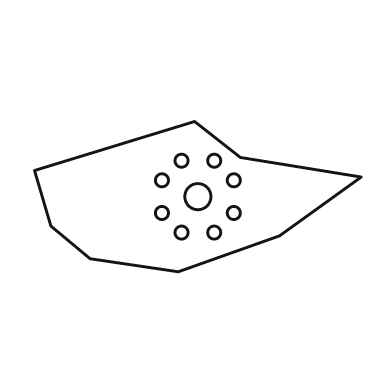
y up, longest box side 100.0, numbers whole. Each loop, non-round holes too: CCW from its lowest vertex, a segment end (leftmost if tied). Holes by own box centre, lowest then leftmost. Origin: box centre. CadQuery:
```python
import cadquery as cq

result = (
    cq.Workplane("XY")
    .moveTo(-6.0, -23.0)
    .lineTo(25.0, -12.0)
    .lineTo(50.0, 6.0)
    .lineTo(13.0, 12.0)
    .lineTo(-1.0, 23.0)
    .lineTo(-50.0, 8.0)
    .lineTo(-45.0, -9.0)
    .lineTo(-33.0, -19.0)
    .close()
    .moveTo(-5.0, -11.0)
    .circle(2.0)
    .moveTo(5.0, -11.0)
    .circle(2.0)
    .moveTo(-11.0, -5.0)
    .circle(2.0)
    .moveTo(11.0, -5.0)
    .circle(2.0)
    .moveTo(0.0, 0.0)
    .circle(4.0)
    .moveTo(-11.0, 5.0)
    .circle(2.0)
    .moveTo(11.0, 5.0)
    .circle(2.0)
    .moveTo(-5.0, 11.0)
    .circle(2.0)
    .moveTo(5.0, 11.0)
    .circle(2.0)
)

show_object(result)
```